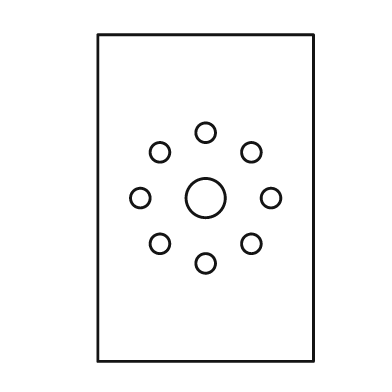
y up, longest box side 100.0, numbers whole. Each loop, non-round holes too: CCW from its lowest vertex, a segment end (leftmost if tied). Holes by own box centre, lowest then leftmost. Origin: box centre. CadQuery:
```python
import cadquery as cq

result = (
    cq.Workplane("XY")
    .moveTo(-33.0, -50.0)
    .lineTo(33.0, -50.0)
    .lineTo(33.0, 50.0)
    .lineTo(-33.0, 50.0)
    .close()
    .moveTo(0.0, -20.0)
    .circle(3.0)
    .moveTo(-14.0, -14.0)
    .circle(3.0)
    .moveTo(14.0, -14.0)
    .circle(3.0)
    .moveTo(-20.0, 0.0)
    .circle(3.0)
    .moveTo(0.0, 0.0)
    .circle(6.0)
    .moveTo(20.0, 0.0)
    .circle(3.0)
    .moveTo(-14.0, 14.0)
    .circle(3.0)
    .moveTo(14.0, 14.0)
    .circle(3.0)
    .moveTo(0.0, 20.0)
    .circle(3.0)
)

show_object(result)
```